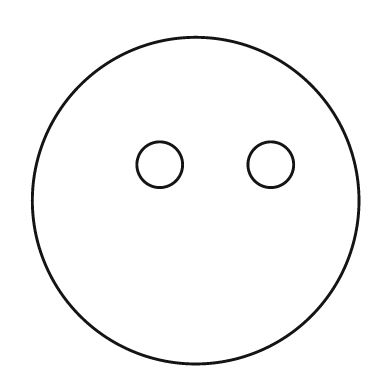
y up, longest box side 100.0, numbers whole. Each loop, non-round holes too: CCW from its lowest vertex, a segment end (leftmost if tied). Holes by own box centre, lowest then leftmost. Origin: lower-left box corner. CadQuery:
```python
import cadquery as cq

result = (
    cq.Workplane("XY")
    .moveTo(50.0, 50.0)
    .circle(50.0)
    .moveTo(39.0, 61.0)
    .circle(7.0)
    .moveTo(73.0, 61.0)
    .circle(7.0)
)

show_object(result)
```